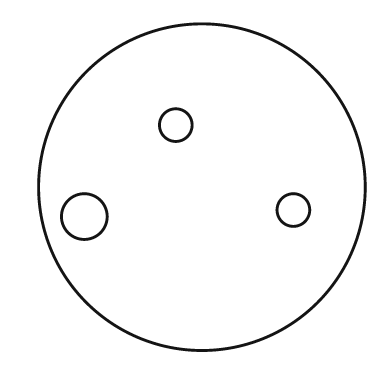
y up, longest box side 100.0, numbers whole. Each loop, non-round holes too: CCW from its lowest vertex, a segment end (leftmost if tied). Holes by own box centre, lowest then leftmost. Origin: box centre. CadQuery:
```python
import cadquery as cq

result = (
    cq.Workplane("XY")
    .moveTo(0.0, 0.0)
    .circle(50.0)
    .moveTo(-36.0, -9.0)
    .circle(7.0)
    .moveTo(28.0, -7.0)
    .circle(5.0)
    .moveTo(-8.0, 19.0)
    .circle(5.0)
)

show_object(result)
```